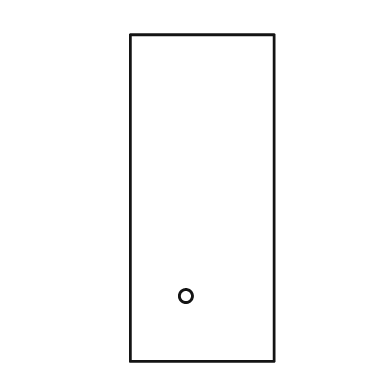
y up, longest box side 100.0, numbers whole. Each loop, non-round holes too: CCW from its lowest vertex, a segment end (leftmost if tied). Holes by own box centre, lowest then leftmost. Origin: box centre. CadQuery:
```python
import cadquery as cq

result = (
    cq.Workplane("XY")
    .moveTo(-22.0, -50.0)
    .lineTo(22.0, -50.0)
    .lineTo(22.0, 50.0)
    .lineTo(-22.0, 50.0)
    .close()
    .moveTo(-5.0, -30.0)
    .circle(2.0)
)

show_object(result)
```